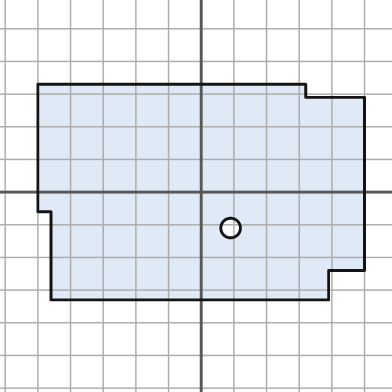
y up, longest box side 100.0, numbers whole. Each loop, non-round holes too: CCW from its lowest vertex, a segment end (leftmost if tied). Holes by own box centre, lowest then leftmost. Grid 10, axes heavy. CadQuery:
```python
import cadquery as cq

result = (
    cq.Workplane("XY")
    .moveTo(-46.0, -33.0)
    .lineTo(39.0, -33.0)
    .lineTo(39.0, -24.0)
    .lineTo(50.0, -24.0)
    .lineTo(50.0, 29.0)
    .lineTo(32.0, 29.0)
    .lineTo(32.0, 33.0)
    .lineTo(-50.0, 33.0)
    .lineTo(-50.0, -6.0)
    .lineTo(-46.0, -6.0)
    .close()
    .moveTo(9.0, -11.0)
    .circle(3.0)
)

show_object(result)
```